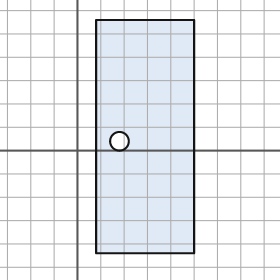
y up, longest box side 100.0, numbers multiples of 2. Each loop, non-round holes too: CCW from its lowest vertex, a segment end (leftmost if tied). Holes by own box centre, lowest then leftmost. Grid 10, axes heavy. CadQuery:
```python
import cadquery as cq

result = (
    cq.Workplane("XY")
    .moveTo(8.0, -44.0)
    .lineTo(50.0, -44.0)
    .lineTo(50.0, 56.0)
    .lineTo(8.0, 56.0)
    .close()
    .moveTo(18.0, 4.0)
    .circle(4.0)
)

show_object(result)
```